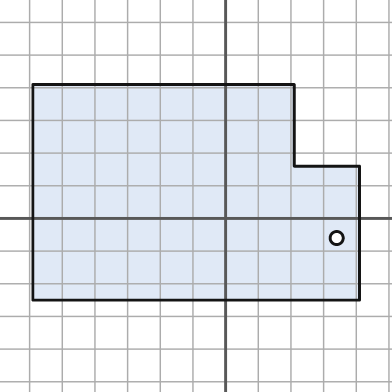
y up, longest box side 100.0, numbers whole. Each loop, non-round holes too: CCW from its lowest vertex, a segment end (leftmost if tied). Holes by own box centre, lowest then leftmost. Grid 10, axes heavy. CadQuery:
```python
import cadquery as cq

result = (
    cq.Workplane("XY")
    .moveTo(-59.0, -25.0)
    .lineTo(41.0, -25.0)
    .lineTo(41.0, 16.0)
    .lineTo(21.0, 16.0)
    .lineTo(21.0, 41.0)
    .lineTo(-59.0, 41.0)
    .close()
    .moveTo(34.0, -6.0)
    .circle(2.0)
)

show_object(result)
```